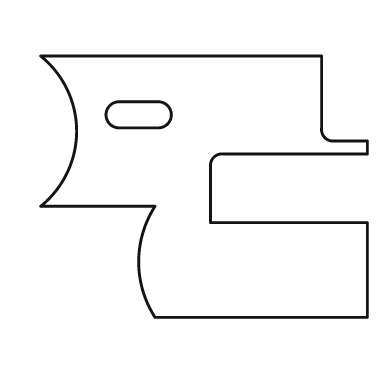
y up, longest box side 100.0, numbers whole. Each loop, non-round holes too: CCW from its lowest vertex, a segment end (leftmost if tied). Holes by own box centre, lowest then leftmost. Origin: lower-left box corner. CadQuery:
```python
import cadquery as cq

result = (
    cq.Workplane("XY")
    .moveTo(35.0, 0.0)
    .lineTo(100.0, 0.0)
    .lineTo(100.0, 29.0)
    .lineTo(52.0, 29.0)
    .lineTo(52.0, 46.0)
    .threePointArc((53.0, 49.0), (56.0, 50.0))
    .lineTo(100.0, 50.0)
    .lineTo(100.0, 54.0)
    .lineTo(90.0, 54.0)
    .threePointArc((87.0, 55.0), (86.0, 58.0))
    .lineTo(86.0, 80.0)
    .lineTo(0.0, 80.0)
    .threePointArc((11.0, 57.0), (0.0, 34.0))
    .lineTo(35.0, 34.0)
    .threePointArc((30.0, 17.0), (35.0, 0.0))
    .close()
    .moveTo(24.0, 58.0)
    .lineTo(36.0, 58.0)
    .threePointArc((40.0, 62.0), (36.0, 66.0))
    .lineTo(24.0, 66.0)
    .threePointArc((20.0, 62.0), (24.0, 58.0))
    .close()
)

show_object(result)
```